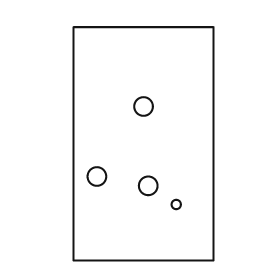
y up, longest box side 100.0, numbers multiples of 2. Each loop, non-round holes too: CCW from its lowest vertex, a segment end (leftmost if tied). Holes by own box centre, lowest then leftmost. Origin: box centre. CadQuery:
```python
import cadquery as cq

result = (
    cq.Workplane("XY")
    .moveTo(-30.0, -50.0)
    .lineTo(30.0, -50.0)
    .lineTo(30.0, 50.0)
    .lineTo(-30.0, 50.0)
    .close()
    .moveTo(14.0, -26.0)
    .circle(2.0)
    .moveTo(2.0, -18.0)
    .circle(4.0)
    .moveTo(-20.0, -14.0)
    .circle(4.0)
    .moveTo(0.0, 16.0)
    .circle(4.0)
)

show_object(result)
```